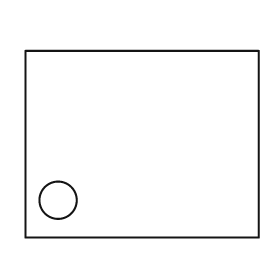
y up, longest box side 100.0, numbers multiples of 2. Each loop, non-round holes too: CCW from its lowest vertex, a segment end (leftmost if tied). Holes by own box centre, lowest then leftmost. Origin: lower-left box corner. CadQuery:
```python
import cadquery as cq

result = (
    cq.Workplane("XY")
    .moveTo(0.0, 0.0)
    .lineTo(100.0, 0.0)
    .lineTo(100.0, 80.0)
    .lineTo(0.0, 80.0)
    .close()
    .moveTo(14.0, 16.0)
    .circle(8.0)
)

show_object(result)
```